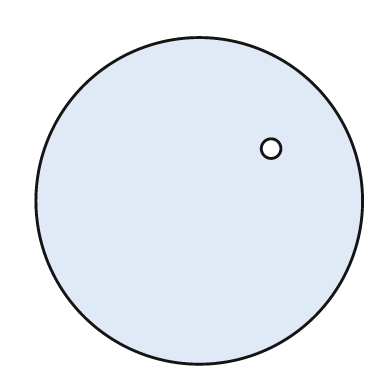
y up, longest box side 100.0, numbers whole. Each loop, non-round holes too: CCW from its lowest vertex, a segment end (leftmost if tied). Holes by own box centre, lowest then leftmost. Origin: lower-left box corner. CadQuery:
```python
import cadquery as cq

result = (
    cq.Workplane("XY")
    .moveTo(50.0, 50.0)
    .circle(50.0)
    .moveTo(72.0, 66.0)
    .circle(3.0)
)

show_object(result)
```